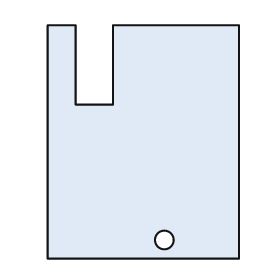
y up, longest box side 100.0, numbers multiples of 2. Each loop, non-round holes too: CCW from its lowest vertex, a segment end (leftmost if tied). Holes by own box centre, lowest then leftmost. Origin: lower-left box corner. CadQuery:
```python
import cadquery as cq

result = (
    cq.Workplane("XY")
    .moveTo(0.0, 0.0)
    .lineTo(82.0, 0.0)
    .lineTo(82.0, 100.0)
    .lineTo(28.0, 100.0)
    .lineTo(28.0, 66.0)
    .lineTo(12.0, 66.0)
    .lineTo(12.0, 100.0)
    .lineTo(0.0, 100.0)
    .close()
    .moveTo(50.0, 8.0)
    .circle(4.0)
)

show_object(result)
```